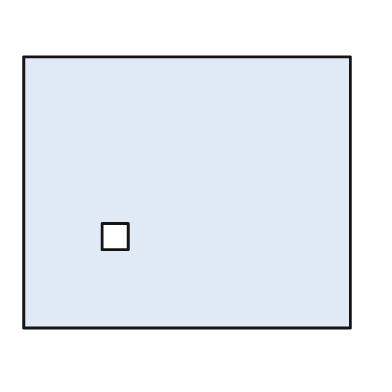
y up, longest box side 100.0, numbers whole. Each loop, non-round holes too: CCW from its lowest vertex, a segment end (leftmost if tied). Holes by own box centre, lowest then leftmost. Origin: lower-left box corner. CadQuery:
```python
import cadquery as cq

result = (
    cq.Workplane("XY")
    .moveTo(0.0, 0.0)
    .lineTo(100.0, 0.0)
    .lineTo(100.0, 83.0)
    .lineTo(0.0, 83.0)
    .close()
    .moveTo(24.0, 24.0)
    .lineTo(32.0, 24.0)
    .lineTo(32.0, 32.0)
    .lineTo(24.0, 32.0)
    .close()
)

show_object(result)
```